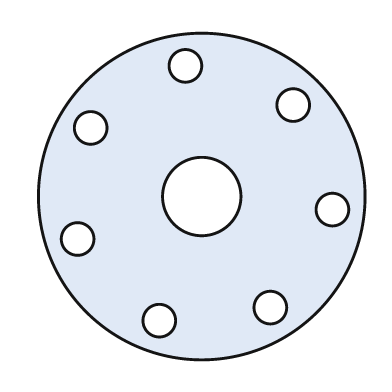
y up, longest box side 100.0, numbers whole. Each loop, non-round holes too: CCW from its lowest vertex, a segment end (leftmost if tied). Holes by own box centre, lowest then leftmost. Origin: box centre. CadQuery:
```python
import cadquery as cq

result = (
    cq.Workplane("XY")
    .moveTo(0.0, 0.0)
    .circle(50.0)
    .moveTo(-13.0, -38.0)
    .circle(5.0)
    .moveTo(21.0, -34.0)
    .circle(5.0)
    .moveTo(-38.0, -13.0)
    .circle(5.0)
    .moveTo(40.0, -4.0)
    .circle(5.0)
    .moveTo(0.0, 0.0)
    .circle(12.0)
    .moveTo(-34.0, 21.0)
    .circle(5.0)
    .moveTo(28.0, 28.0)
    .circle(5.0)
    .moveTo(-5.0, 40.0)
    .circle(5.0)
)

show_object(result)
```